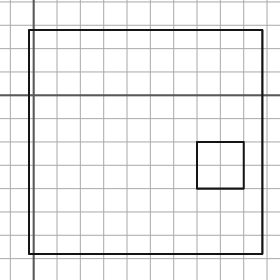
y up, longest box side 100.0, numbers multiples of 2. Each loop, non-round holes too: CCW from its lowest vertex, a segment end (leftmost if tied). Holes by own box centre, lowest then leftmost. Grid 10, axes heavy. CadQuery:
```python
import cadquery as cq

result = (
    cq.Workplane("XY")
    .moveTo(-2.0, -68.0)
    .lineTo(98.0, -68.0)
    .lineTo(98.0, 28.0)
    .lineTo(-2.0, 28.0)
    .close()
    .moveTo(70.0, -40.0)
    .lineTo(90.0, -40.0)
    .lineTo(90.0, -20.0)
    .lineTo(70.0, -20.0)
    .close()
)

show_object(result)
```